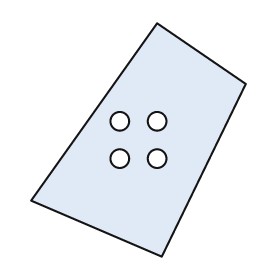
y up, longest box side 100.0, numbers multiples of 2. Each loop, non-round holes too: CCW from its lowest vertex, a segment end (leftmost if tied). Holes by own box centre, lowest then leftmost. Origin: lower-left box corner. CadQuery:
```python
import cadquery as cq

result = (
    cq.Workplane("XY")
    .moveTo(56.0, 0.0)
    .lineTo(92.0, 74.0)
    .lineTo(54.0, 100.0)
    .lineTo(0.0, 24.0)
    .close()
    .moveTo(38.0, 42.0)
    .circle(4.0)
    .moveTo(54.0, 42.0)
    .circle(4.0)
    .moveTo(38.0, 58.0)
    .circle(4.0)
    .moveTo(54.0, 58.0)
    .circle(4.0)
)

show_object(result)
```